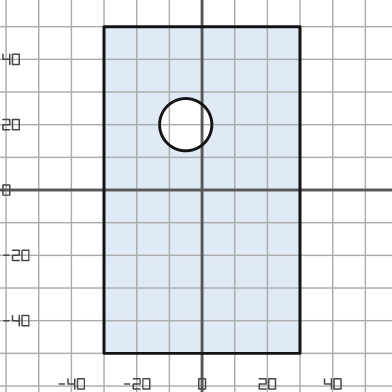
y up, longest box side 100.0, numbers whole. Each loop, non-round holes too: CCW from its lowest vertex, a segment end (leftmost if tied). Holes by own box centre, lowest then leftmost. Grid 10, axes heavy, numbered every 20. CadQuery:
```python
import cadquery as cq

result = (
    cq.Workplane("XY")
    .moveTo(-30.0, -50.0)
    .lineTo(30.0, -50.0)
    .lineTo(30.0, 50.0)
    .lineTo(-30.0, 50.0)
    .close()
    .moveTo(-5.0, 20.0)
    .circle(8.0)
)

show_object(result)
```